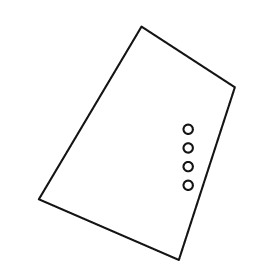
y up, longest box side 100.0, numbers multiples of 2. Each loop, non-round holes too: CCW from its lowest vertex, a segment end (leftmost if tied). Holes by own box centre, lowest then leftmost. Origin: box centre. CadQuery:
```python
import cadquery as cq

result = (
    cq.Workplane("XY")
    .moveTo(18.0, -50.0)
    .lineTo(42.0, 24.0)
    .lineTo(2.0, 50.0)
    .lineTo(-42.0, -24.0)
    .close()
    .moveTo(22.0, -18.0)
    .circle(2.0)
    .moveTo(22.0, -10.0)
    .circle(2.0)
    .moveTo(22.0, -2.0)
    .circle(2.0)
    .moveTo(22.0, 6.0)
    .circle(2.0)
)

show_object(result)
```